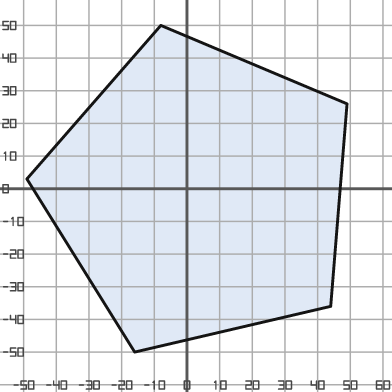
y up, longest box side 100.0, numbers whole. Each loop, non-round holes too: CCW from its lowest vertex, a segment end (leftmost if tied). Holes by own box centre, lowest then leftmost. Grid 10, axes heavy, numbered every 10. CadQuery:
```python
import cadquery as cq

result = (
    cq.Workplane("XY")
    .moveTo(-16.0, -50.0)
    .lineTo(44.0, -36.0)
    .lineTo(49.0, 26.0)
    .lineTo(-8.0, 50.0)
    .lineTo(-49.0, 3.0)
    .close()
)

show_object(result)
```